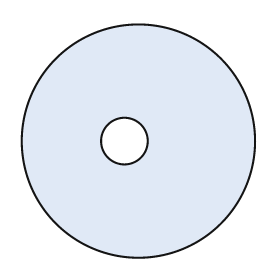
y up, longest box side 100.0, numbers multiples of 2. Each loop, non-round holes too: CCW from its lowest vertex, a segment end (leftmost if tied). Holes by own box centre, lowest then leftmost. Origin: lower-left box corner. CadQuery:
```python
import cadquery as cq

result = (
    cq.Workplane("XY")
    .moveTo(50.0, 50.0)
    .circle(50.0)
    .moveTo(44.0, 50.0)
    .circle(10.0)
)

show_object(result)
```